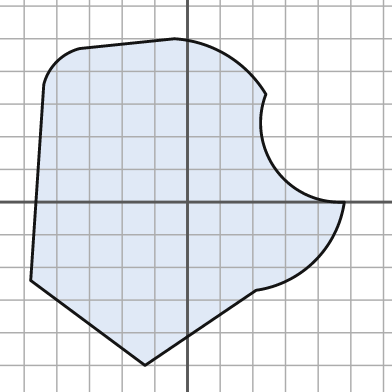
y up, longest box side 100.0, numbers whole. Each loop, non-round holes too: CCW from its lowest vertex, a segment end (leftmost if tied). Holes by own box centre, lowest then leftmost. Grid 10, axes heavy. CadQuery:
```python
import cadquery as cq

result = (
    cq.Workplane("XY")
    .moveTo(-13.0, -50.0)
    .lineTo(21.0, -27.0)
    .threePointArc((39.0, -18.0), (48.0, 0.0))
    .threePointArc((27.0, 10.0), (24.0, 33.0))
    .threePointArc((12.0, 45.0), (-4.0, 50.0))
    .lineTo(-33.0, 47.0)
    .threePointArc((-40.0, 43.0), (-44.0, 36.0))
    .lineTo(-48.0, -24.0)
    .close()
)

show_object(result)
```